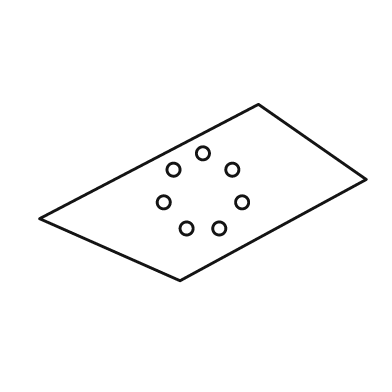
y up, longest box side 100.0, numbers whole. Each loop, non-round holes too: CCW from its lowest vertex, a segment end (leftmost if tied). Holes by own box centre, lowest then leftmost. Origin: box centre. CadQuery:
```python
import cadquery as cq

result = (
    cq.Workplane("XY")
    .moveTo(-7.0, -27.0)
    .lineTo(50.0, 4.0)
    .lineTo(17.0, 27.0)
    .lineTo(-50.0, -8.0)
    .close()
    .moveTo(-5.0, -11.0)
    .circle(2.0)
    .moveTo(5.0, -11.0)
    .circle(2.0)
    .moveTo(-12.0, -3.0)
    .circle(2.0)
    .moveTo(12.0, -3.0)
    .circle(2.0)
    .moveTo(-9.0, 7.0)
    .circle(2.0)
    .moveTo(9.0, 7.0)
    .circle(2.0)
    .moveTo(0.0, 12.0)
    .circle(2.0)
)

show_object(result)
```